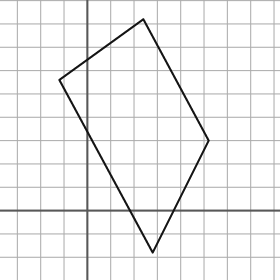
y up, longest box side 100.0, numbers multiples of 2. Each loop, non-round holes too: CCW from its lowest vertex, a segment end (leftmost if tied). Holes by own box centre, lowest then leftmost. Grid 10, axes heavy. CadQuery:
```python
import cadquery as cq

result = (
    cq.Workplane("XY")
    .moveTo(28.0, -18.0)
    .lineTo(52.0, 30.0)
    .lineTo(24.0, 82.0)
    .lineTo(-12.0, 56.0)
    .close()
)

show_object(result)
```